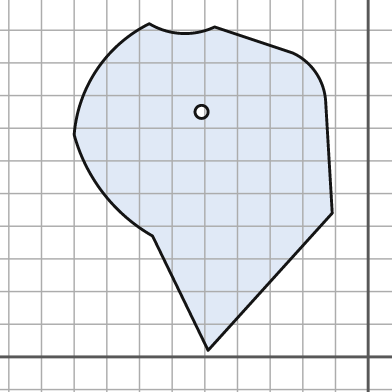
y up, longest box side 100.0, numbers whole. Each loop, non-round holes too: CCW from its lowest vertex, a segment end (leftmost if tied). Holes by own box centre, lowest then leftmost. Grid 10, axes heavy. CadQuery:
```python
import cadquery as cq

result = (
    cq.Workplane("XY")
    .moveTo(-49.0, 2.0)
    .lineTo(-11.0, 44.0)
    .lineTo(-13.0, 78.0)
    .threePointArc((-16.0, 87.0), (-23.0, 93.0))
    .lineTo(-47.0, 101.0)
    .threePointArc((-57.0, 99.0), (-67.0, 102.0))
    .threePointArc((-83.0, 88.0), (-90.0, 68.0))
    .threePointArc((-81.0, 50.0), (-66.0, 37.0))
    .close()
    .moveTo(-51.0, 75.0)
    .circle(2.0)
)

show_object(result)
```